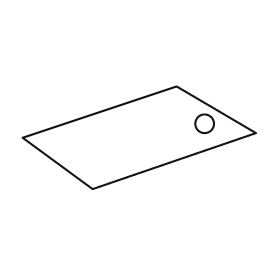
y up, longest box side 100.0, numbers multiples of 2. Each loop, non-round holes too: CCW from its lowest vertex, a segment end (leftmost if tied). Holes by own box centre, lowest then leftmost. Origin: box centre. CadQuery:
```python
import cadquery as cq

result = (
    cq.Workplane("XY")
    .moveTo(-20.0, -22.0)
    .lineTo(50.0, 2.0)
    .lineTo(16.0, 22.0)
    .lineTo(-50.0, 0.0)
    .close()
    .moveTo(28.0, 6.0)
    .circle(4.0)
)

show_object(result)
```